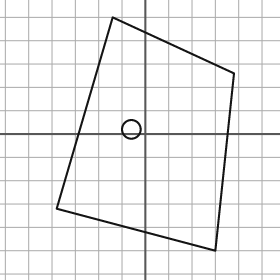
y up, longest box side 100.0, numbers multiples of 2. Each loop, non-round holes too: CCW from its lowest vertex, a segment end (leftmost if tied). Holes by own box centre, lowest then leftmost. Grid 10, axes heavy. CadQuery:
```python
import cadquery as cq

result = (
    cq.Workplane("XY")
    .moveTo(30.0, -50.0)
    .lineTo(38.0, 26.0)
    .lineTo(-14.0, 50.0)
    .lineTo(-38.0, -32.0)
    .close()
    .moveTo(-6.0, 2.0)
    .circle(4.0)
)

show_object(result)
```